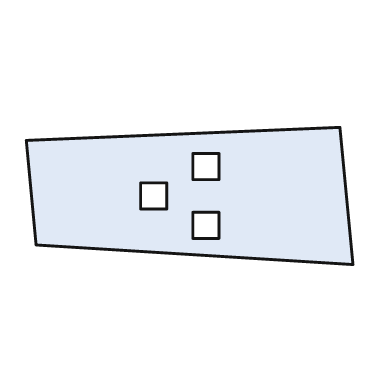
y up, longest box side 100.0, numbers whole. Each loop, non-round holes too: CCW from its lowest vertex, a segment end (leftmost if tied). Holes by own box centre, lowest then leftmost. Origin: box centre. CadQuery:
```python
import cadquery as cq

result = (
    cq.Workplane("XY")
    .moveTo(50.0, -21.0)
    .lineTo(46.0, 21.0)
    .lineTo(-50.0, 17.0)
    .lineTo(-47.0, -15.0)
    .close()
    .moveTo(1.0, -13.0)
    .lineTo(9.0, -13.0)
    .lineTo(9.0, -5.0)
    .lineTo(1.0, -5.0)
    .close()
    .moveTo(-15.0, -4.0)
    .lineTo(-7.0, -4.0)
    .lineTo(-7.0, 4.0)
    .lineTo(-15.0, 4.0)
    .close()
    .moveTo(1.0, 5.0)
    .lineTo(9.0, 5.0)
    .lineTo(9.0, 13.0)
    .lineTo(1.0, 13.0)
    .close()
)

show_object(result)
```